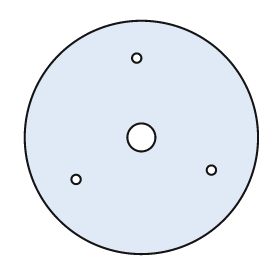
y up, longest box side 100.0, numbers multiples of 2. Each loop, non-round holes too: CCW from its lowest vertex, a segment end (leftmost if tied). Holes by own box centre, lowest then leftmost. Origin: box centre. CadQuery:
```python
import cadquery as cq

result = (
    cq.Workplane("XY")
    .moveTo(0.0, 0.0)
    .circle(50.0)
    .moveTo(-28.0, -18.0)
    .circle(2.0)
    .moveTo(30.0, -14.0)
    .circle(2.0)
    .moveTo(0.0, 0.0)
    .circle(6.0)
    .moveTo(-2.0, 34.0)
    .circle(2.0)
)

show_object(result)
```